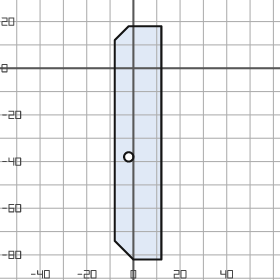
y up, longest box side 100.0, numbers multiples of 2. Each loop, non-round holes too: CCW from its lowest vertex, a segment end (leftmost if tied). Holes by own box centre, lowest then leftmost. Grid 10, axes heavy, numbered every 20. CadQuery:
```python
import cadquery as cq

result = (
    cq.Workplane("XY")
    .moveTo(0.0, -82.0)
    .lineTo(12.0, -82.0)
    .lineTo(12.0, 18.0)
    .lineTo(-2.0, 18.0)
    .lineTo(-8.0, 12.0)
    .lineTo(-8.0, -74.0)
    .close()
    .moveTo(-2.0, -38.0)
    .circle(2.0)
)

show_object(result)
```